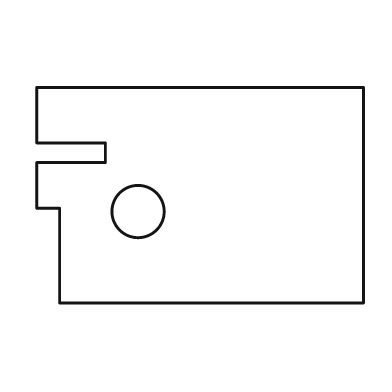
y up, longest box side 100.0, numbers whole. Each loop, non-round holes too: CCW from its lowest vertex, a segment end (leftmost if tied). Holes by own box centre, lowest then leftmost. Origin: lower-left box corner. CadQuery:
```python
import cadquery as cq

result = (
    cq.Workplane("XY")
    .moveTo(7.0, 0.0)
    .lineTo(100.0, 0.0)
    .lineTo(100.0, 66.0)
    .lineTo(0.0, 66.0)
    .lineTo(0.0, 49.0)
    .lineTo(21.0, 49.0)
    .lineTo(21.0, 43.0)
    .lineTo(0.0, 43.0)
    .lineTo(0.0, 29.0)
    .lineTo(7.0, 29.0)
    .close()
    .moveTo(31.0, 28.0)
    .circle(8.0)
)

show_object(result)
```